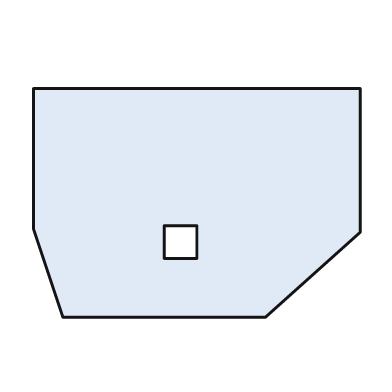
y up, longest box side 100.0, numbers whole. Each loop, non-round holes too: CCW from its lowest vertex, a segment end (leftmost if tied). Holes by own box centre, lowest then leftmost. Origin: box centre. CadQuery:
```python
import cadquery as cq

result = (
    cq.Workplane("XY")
    .moveTo(-41.0, -35.0)
    .lineTo(21.0, -35.0)
    .lineTo(50.0, -9.0)
    .lineTo(50.0, 35.0)
    .lineTo(-50.0, 35.0)
    .lineTo(-50.0, -8.0)
    .close()
    .moveTo(-10.0, -17.0)
    .lineTo(0.0, -17.0)
    .lineTo(0.0, -7.0)
    .lineTo(-10.0, -7.0)
    .close()
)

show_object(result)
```